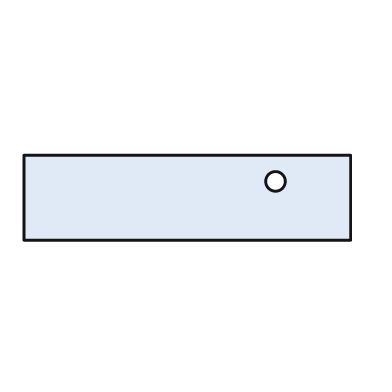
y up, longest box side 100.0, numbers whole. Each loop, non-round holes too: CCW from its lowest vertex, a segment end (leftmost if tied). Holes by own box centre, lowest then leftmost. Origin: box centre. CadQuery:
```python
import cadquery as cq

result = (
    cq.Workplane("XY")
    .moveTo(-50.0, -13.0)
    .lineTo(50.0, -13.0)
    .lineTo(50.0, 13.0)
    .lineTo(-50.0, 13.0)
    .close()
    .moveTo(27.0, 5.0)
    .circle(3.0)
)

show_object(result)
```